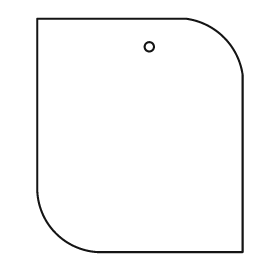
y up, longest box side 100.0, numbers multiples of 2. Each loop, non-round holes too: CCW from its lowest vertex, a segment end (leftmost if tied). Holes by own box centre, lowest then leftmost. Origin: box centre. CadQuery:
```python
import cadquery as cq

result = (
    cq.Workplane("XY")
    .moveTo(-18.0, -50.0)
    .lineTo(44.0, -50.0)
    .lineTo(44.0, 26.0)
    .threePointArc((36.0, 42.0), (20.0, 50.0))
    .lineTo(-44.0, 50.0)
    .lineTo(-44.0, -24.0)
    .threePointArc((-36.0, -42.0), (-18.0, -50.0))
    .close()
    .moveTo(4.0, 38.0)
    .circle(2.0)
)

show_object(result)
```